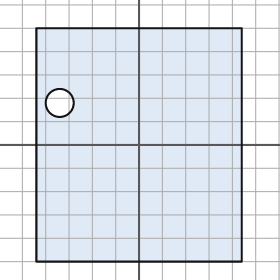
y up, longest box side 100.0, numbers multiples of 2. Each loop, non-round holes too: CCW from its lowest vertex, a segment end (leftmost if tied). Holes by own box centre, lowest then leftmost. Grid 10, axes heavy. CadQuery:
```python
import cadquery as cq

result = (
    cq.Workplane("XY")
    .moveTo(-44.0, -50.0)
    .lineTo(44.0, -50.0)
    .lineTo(44.0, 50.0)
    .lineTo(-44.0, 50.0)
    .close()
    .moveTo(-34.0, 18.0)
    .circle(6.0)
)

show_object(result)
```